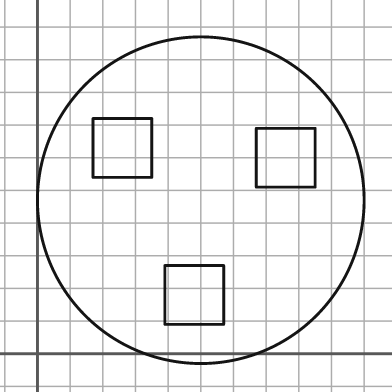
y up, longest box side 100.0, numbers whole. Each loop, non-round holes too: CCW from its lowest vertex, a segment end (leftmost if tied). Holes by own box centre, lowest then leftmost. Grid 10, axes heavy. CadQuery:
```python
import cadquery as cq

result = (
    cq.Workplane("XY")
    .moveTo(50.0, 47.0)
    .circle(50.0)
    .moveTo(39.0, 9.0)
    .lineTo(57.0, 9.0)
    .lineTo(57.0, 27.0)
    .lineTo(39.0, 27.0)
    .close()
    .moveTo(67.0, 51.0)
    .lineTo(85.0, 51.0)
    .lineTo(85.0, 69.0)
    .lineTo(67.0, 69.0)
    .close()
    .moveTo(17.0, 54.0)
    .lineTo(35.0, 54.0)
    .lineTo(35.0, 72.0)
    .lineTo(17.0, 72.0)
    .close()
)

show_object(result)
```